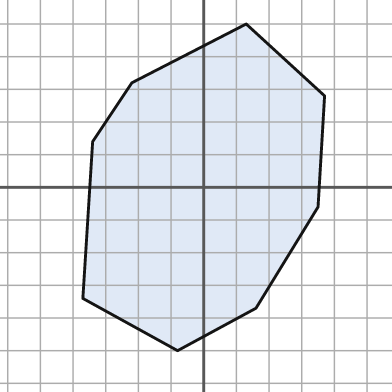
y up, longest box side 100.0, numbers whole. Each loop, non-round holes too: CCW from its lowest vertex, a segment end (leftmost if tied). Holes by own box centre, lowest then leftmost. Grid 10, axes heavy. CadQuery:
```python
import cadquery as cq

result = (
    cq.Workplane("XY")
    .moveTo(-8.0, -50.0)
    .lineTo(16.0, -37.0)
    .lineTo(35.0, -6.0)
    .lineTo(37.0, 28.0)
    .lineTo(13.0, 50.0)
    .lineTo(-22.0, 32.0)
    .lineTo(-34.0, 14.0)
    .lineTo(-37.0, -34.0)
    .close()
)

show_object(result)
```